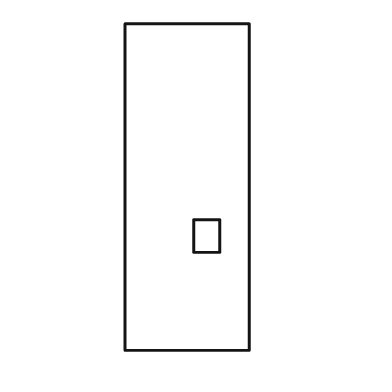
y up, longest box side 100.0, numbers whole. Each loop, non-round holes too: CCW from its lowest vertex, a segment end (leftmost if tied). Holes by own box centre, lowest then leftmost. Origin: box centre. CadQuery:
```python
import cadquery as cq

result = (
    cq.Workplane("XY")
    .moveTo(-19.0, -50.0)
    .lineTo(19.0, -50.0)
    .lineTo(19.0, 50.0)
    .lineTo(-19.0, 50.0)
    .close()
    .moveTo(2.0, -20.0)
    .lineTo(10.0, -20.0)
    .lineTo(10.0, -10.0)
    .lineTo(2.0, -10.0)
    .close()
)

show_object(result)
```